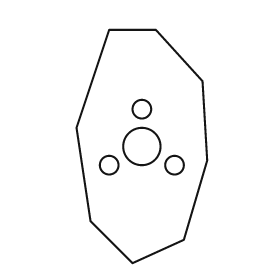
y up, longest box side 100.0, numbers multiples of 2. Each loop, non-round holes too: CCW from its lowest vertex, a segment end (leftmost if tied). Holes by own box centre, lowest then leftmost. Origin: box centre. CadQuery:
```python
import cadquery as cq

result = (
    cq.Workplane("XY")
    .moveTo(-4.0, -50.0)
    .lineTo(18.0, -40.0)
    .lineTo(28.0, -6.0)
    .lineTo(26.0, 28.0)
    .lineTo(6.0, 50.0)
    .lineTo(-14.0, 50.0)
    .lineTo(-28.0, 8.0)
    .lineTo(-22.0, -32.0)
    .close()
    .moveTo(-14.0, -8.0)
    .circle(4.0)
    .moveTo(14.0, -8.0)
    .circle(4.0)
    .moveTo(0.0, 0.0)
    .circle(8.0)
    .moveTo(0.0, 16.0)
    .circle(4.0)
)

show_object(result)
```